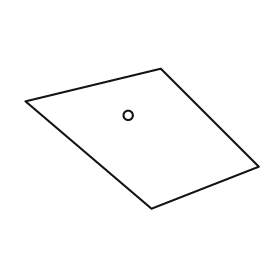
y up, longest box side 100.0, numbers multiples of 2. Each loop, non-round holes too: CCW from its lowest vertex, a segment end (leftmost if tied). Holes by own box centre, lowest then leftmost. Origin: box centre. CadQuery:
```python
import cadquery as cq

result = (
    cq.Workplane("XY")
    .moveTo(4.0, -30.0)
    .lineTo(50.0, -12.0)
    .lineTo(8.0, 30.0)
    .lineTo(-50.0, 16.0)
    .close()
    .moveTo(-6.0, 10.0)
    .circle(2.0)
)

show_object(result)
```